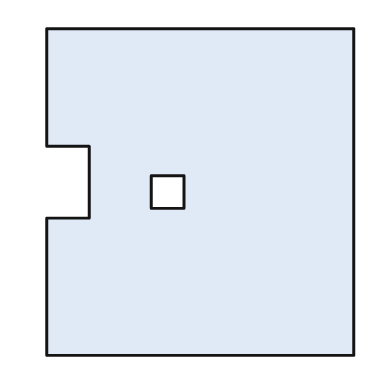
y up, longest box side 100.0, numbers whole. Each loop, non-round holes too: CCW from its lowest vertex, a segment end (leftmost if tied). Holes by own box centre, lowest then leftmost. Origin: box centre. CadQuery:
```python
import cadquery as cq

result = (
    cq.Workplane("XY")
    .moveTo(-47.0, -50.0)
    .lineTo(47.0, -50.0)
    .lineTo(47.0, 50.0)
    .lineTo(-47.0, 50.0)
    .lineTo(-47.0, 14.0)
    .lineTo(-34.0, 14.0)
    .lineTo(-34.0, -8.0)
    .lineTo(-47.0, -8.0)
    .close()
    .moveTo(-15.0, -5.0)
    .lineTo(-5.0, -5.0)
    .lineTo(-5.0, 5.0)
    .lineTo(-15.0, 5.0)
    .close()
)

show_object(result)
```